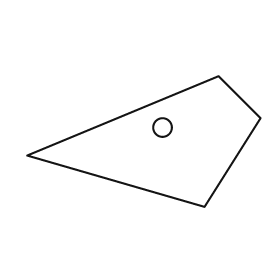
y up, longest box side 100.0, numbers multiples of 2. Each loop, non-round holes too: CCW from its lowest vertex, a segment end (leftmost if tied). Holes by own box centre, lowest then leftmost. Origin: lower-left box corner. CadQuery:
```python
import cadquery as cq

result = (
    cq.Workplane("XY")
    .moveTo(76.0, 0.0)
    .lineTo(100.0, 38.0)
    .lineTo(82.0, 56.0)
    .lineTo(0.0, 22.0)
    .close()
    .moveTo(58.0, 34.0)
    .circle(4.0)
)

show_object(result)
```